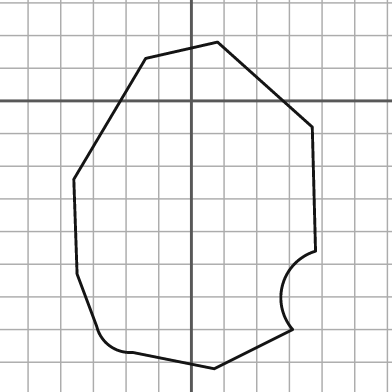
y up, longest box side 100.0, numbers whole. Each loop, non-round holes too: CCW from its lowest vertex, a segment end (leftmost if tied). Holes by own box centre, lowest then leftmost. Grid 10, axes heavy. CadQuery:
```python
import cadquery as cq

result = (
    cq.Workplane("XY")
    .moveTo(7.0, -82.0)
    .lineTo(31.0, -70.0)
    .threePointArc((28.0, -56.0), (38.0, -46.0))
    .lineTo(37.0, -8.0)
    .lineTo(8.0, 18.0)
    .lineTo(-14.0, 13.0)
    .lineTo(-36.0, -24.0)
    .lineTo(-35.0, -53.0)
    .lineTo(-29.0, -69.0)
    .threePointArc((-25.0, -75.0), (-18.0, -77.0))
    .close()
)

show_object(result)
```